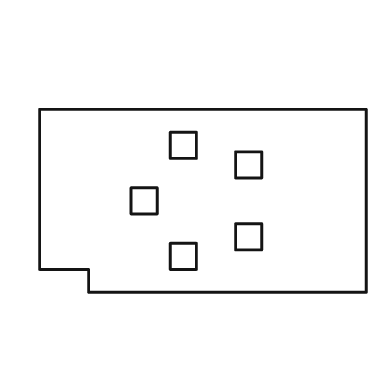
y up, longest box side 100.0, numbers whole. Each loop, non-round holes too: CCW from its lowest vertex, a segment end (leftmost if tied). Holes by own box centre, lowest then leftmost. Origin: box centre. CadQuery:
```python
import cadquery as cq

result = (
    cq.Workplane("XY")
    .moveTo(-35.0, -28.0)
    .lineTo(50.0, -28.0)
    .lineTo(50.0, 28.0)
    .lineTo(-50.0, 28.0)
    .lineTo(-50.0, -21.0)
    .lineTo(-35.0, -21.0)
    .close()
    .moveTo(-10.0, -21.0)
    .lineTo(-2.0, -21.0)
    .lineTo(-2.0, -13.0)
    .lineTo(-10.0, -13.0)
    .close()
    .moveTo(10.0, -15.0)
    .lineTo(18.0, -15.0)
    .lineTo(18.0, -7.0)
    .lineTo(10.0, -7.0)
    .close()
    .moveTo(-22.0, -4.0)
    .lineTo(-14.0, -4.0)
    .lineTo(-14.0, 4.0)
    .lineTo(-22.0, 4.0)
    .close()
    .moveTo(10.0, 7.0)
    .lineTo(18.0, 7.0)
    .lineTo(18.0, 15.0)
    .lineTo(10.0, 15.0)
    .close()
    .moveTo(-10.0, 13.0)
    .lineTo(-2.0, 13.0)
    .lineTo(-2.0, 21.0)
    .lineTo(-10.0, 21.0)
    .close()
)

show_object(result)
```